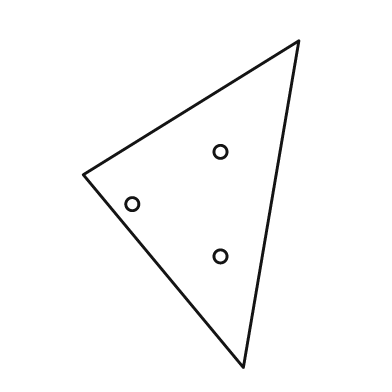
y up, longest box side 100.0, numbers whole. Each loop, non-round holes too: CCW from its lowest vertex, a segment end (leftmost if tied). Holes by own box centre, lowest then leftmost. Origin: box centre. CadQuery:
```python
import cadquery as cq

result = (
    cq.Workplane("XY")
    .moveTo(16.0, -50.0)
    .lineTo(33.0, 50.0)
    .lineTo(-33.0, 9.0)
    .close()
    .moveTo(9.0, -16.0)
    .circle(2.0)
    .moveTo(-18.0, 0.0)
    .circle(2.0)
    .moveTo(9.0, 16.0)
    .circle(2.0)
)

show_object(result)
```